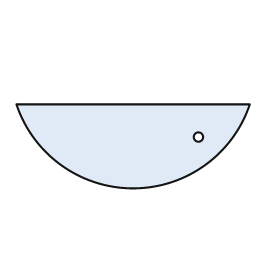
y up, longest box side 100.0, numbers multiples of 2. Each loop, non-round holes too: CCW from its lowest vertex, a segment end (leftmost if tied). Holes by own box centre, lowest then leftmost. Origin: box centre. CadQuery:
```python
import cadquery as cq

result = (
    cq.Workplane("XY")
    .moveTo(-50.0, 18.0)
    .threePointArc((0.0, -18.0), (50.0, 18.0))
    .close()
    .moveTo(28.0, 4.0)
    .circle(2.0)
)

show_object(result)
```